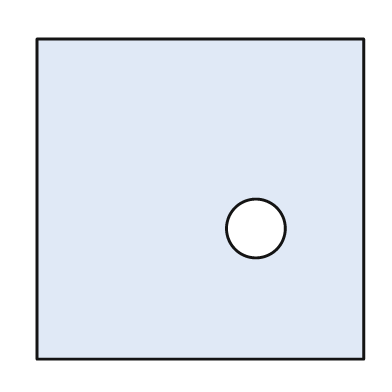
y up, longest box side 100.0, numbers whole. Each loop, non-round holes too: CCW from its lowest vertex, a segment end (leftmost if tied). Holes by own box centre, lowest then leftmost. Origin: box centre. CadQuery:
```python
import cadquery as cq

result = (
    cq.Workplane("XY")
    .moveTo(-50.0, -49.0)
    .lineTo(50.0, -49.0)
    .lineTo(50.0, 49.0)
    .lineTo(-50.0, 49.0)
    .close()
    .moveTo(17.0, -9.0)
    .circle(9.0)
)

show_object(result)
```